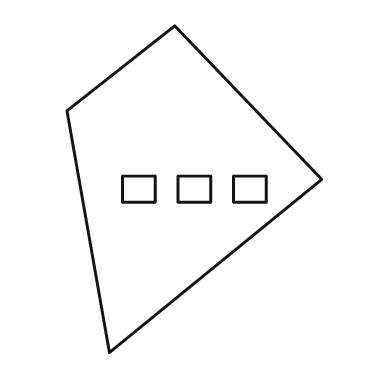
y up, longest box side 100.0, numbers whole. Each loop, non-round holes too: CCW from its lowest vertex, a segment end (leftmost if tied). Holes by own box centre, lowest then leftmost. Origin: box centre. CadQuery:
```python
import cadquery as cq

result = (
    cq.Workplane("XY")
    .moveTo(-26.0, -50.0)
    .lineTo(39.0, 3.0)
    .lineTo(-6.0, 50.0)
    .lineTo(-39.0, 24.0)
    .close()
    .moveTo(-22.0, -4.0)
    .lineTo(-12.0, -4.0)
    .lineTo(-12.0, 4.0)
    .lineTo(-22.0, 4.0)
    .close()
    .moveTo(-5.0, -4.0)
    .lineTo(5.0, -4.0)
    .lineTo(5.0, 4.0)
    .lineTo(-5.0, 4.0)
    .close()
    .moveTo(12.0, -4.0)
    .lineTo(22.0, -4.0)
    .lineTo(22.0, 4.0)
    .lineTo(12.0, 4.0)
    .close()
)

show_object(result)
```